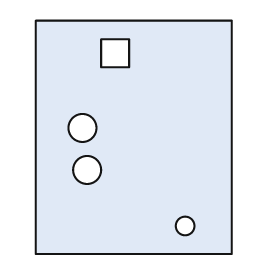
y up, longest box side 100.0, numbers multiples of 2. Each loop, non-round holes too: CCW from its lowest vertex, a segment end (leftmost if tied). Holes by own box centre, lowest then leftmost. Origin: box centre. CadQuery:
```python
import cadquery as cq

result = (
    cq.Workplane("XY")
    .moveTo(-42.0, -50.0)
    .lineTo(42.0, -50.0)
    .lineTo(42.0, 50.0)
    .lineTo(-42.0, 50.0)
    .close()
    .moveTo(22.0, -38.0)
    .circle(4.0)
    .moveTo(-20.0, -14.0)
    .circle(6.0)
    .moveTo(-22.0, 4.0)
    .circle(6.0)
    .moveTo(-14.0, 30.0)
    .lineTo(-2.0, 30.0)
    .lineTo(-2.0, 42.0)
    .lineTo(-14.0, 42.0)
    .close()
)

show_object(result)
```